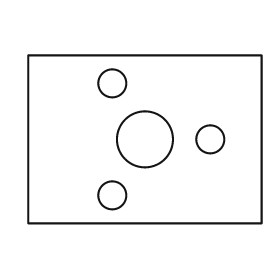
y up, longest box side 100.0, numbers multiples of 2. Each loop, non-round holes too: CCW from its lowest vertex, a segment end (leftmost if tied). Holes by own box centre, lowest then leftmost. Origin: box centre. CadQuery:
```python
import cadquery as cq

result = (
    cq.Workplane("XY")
    .moveTo(-50.0, -36.0)
    .lineTo(50.0, -36.0)
    .lineTo(50.0, 36.0)
    .lineTo(-50.0, 36.0)
    .close()
    .moveTo(-14.0, -24.0)
    .circle(6.0)
    .moveTo(0.0, 0.0)
    .circle(12.0)
    .moveTo(28.0, 0.0)
    .circle(6.0)
    .moveTo(-14.0, 24.0)
    .circle(6.0)
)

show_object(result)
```